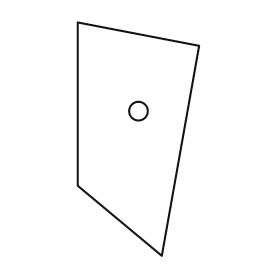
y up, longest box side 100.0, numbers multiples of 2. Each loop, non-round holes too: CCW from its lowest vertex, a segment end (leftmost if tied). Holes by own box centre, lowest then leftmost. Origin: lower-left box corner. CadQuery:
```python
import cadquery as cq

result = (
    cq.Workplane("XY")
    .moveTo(36.0, 0.0)
    .lineTo(52.0, 90.0)
    .lineTo(0.0, 100.0)
    .lineTo(0.0, 30.0)
    .close()
    .moveTo(26.0, 62.0)
    .circle(4.0)
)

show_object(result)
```